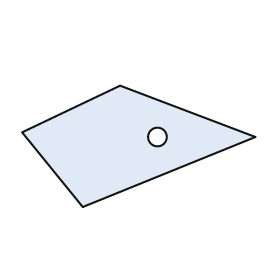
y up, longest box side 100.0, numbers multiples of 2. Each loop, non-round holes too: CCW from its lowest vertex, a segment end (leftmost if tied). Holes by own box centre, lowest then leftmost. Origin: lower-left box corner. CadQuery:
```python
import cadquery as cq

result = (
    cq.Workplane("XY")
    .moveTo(26.0, 0.0)
    .lineTo(100.0, 30.0)
    .lineTo(42.0, 52.0)
    .lineTo(0.0, 32.0)
    .close()
    .moveTo(58.0, 30.0)
    .circle(4.0)
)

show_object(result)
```